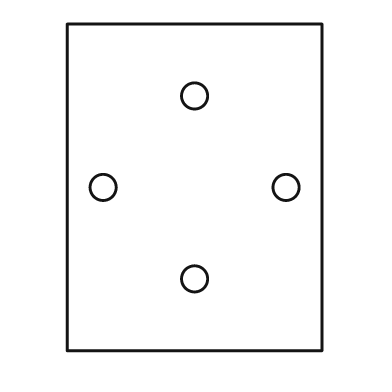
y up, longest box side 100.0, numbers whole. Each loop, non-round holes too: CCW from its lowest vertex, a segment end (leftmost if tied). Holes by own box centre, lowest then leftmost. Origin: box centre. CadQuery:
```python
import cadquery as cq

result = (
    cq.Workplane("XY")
    .moveTo(-39.0, -50.0)
    .lineTo(39.0, -50.0)
    .lineTo(39.0, 50.0)
    .lineTo(-39.0, 50.0)
    .close()
    .moveTo(0.0, -28.0)
    .circle(4.0)
    .moveTo(-28.0, 0.0)
    .circle(4.0)
    .moveTo(28.0, 0.0)
    .circle(4.0)
    .moveTo(0.0, 28.0)
    .circle(4.0)
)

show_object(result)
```